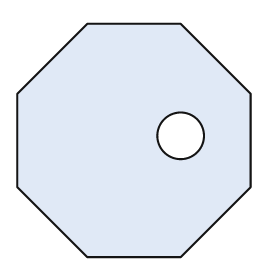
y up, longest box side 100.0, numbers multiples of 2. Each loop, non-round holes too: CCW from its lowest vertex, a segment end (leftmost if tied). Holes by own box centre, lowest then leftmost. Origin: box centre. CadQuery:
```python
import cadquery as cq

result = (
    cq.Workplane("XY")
    .moveTo(-20.0, -50.0)
    .lineTo(20.0, -50.0)
    .lineTo(50.0, -20.0)
    .lineTo(50.0, 20.0)
    .lineTo(20.0, 50.0)
    .lineTo(-20.0, 50.0)
    .lineTo(-50.0, 20.0)
    .lineTo(-50.0, -20.0)
    .close()
    .moveTo(20.0, 2.0)
    .circle(10.0)
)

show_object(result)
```